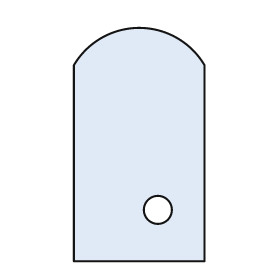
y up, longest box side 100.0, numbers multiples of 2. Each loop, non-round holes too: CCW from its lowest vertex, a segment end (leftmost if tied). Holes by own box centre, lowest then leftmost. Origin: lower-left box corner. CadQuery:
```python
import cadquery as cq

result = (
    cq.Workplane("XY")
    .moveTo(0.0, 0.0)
    .lineTo(56.0, 0.0)
    .lineTo(56.0, 84.0)
    .threePointArc((28.0, 100.0), (0.0, 84.0))
    .close()
    .moveTo(36.0, 22.0)
    .circle(6.0)
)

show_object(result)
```